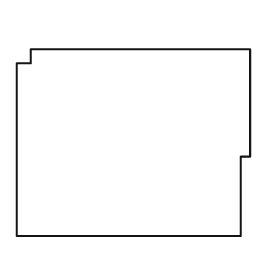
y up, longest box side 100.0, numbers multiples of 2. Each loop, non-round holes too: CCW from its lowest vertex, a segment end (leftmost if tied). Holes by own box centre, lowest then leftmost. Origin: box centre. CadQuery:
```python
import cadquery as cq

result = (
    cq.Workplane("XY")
    .moveTo(-50.0, -40.0)
    .lineTo(46.0, -40.0)
    .lineTo(46.0, -6.0)
    .lineTo(50.0, -6.0)
    .lineTo(50.0, 40.0)
    .lineTo(-44.0, 40.0)
    .lineTo(-44.0, 34.0)
    .lineTo(-50.0, 34.0)
    .close()
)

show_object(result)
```